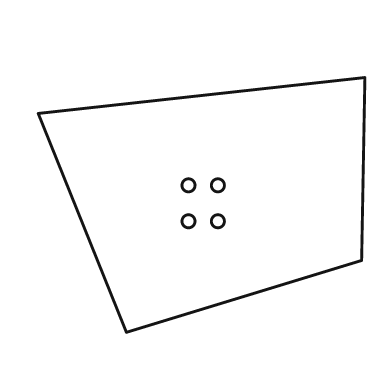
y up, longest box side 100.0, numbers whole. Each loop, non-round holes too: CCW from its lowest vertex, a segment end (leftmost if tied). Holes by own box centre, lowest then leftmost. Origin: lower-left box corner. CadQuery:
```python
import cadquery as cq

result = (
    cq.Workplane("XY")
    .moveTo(27.0, 0.0)
    .lineTo(99.0, 22.0)
    .lineTo(100.0, 78.0)
    .lineTo(0.0, 67.0)
    .close()
    .moveTo(46.0, 34.0)
    .circle(2.0)
    .moveTo(55.0, 34.0)
    .circle(2.0)
    .moveTo(46.0, 45.0)
    .circle(2.0)
    .moveTo(55.0, 45.0)
    .circle(2.0)
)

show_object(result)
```